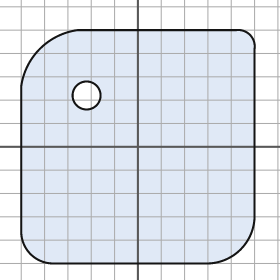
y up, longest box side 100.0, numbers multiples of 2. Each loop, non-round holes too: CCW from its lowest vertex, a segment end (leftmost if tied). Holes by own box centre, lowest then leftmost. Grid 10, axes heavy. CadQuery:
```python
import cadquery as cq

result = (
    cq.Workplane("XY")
    .moveTo(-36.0, -50.0)
    .lineTo(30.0, -50.0)
    .threePointArc((44.0, -44.0), (50.0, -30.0))
    .lineTo(50.0, 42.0)
    .threePointArc((48.0, 48.0), (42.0, 50.0))
    .lineTo(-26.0, 50.0)
    .threePointArc((-42.0, 42.0), (-50.0, 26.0))
    .lineTo(-50.0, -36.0)
    .threePointArc((-46.0, -46.0), (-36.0, -50.0))
    .close()
    .moveTo(-22.0, 22.0)
    .circle(6.0)
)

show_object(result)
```